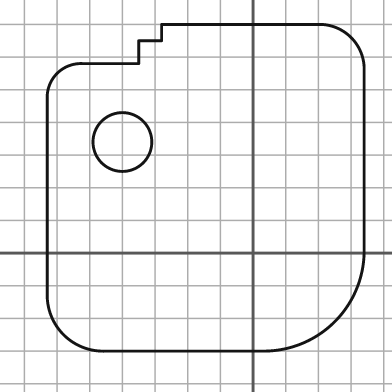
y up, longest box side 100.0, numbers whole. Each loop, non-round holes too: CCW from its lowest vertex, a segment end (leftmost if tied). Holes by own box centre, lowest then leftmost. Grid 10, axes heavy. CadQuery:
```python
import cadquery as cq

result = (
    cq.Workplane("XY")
    .moveTo(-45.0, -30.0)
    .lineTo(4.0, -30.0)
    .threePointArc((25.0, -21.0), (34.0, 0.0))
    .lineTo(34.0, 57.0)
    .threePointArc((30.0, 66.0), (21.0, 70.0))
    .lineTo(-28.0, 70.0)
    .lineTo(-28.0, 65.0)
    .lineTo(-35.0, 65.0)
    .lineTo(-35.0, 58.0)
    .lineTo(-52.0, 58.0)
    .threePointArc((-60.0, 55.0), (-63.0, 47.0))
    .lineTo(-63.0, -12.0)
    .threePointArc((-58.0, -25.0), (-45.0, -30.0))
    .close()
    .moveTo(-40.0, 34.0)
    .circle(9.0)
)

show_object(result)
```